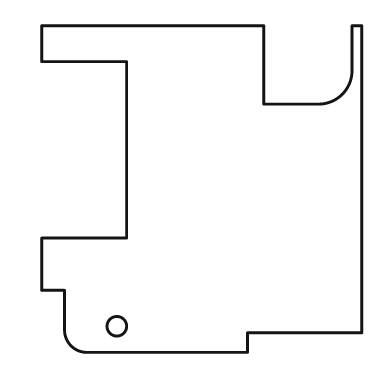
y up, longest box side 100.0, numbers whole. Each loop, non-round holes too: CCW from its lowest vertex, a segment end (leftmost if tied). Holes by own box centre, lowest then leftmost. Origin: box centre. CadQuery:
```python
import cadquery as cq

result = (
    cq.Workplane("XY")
    .moveTo(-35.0, -50.0)
    .lineTo(14.0, -50.0)
    .lineTo(14.0, -44.0)
    .lineTo(49.0, -44.0)
    .lineTo(49.0, 50.0)
    .lineTo(46.0, 50.0)
    .lineTo(46.0, 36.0)
    .threePointArc((43.0, 29.0), (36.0, 26.0))
    .lineTo(19.0, 26.0)
    .lineTo(19.0, 50.0)
    .lineTo(-49.0, 50.0)
    .lineTo(-49.0, 39.0)
    .lineTo(-23.0, 39.0)
    .lineTo(-23.0, -15.0)
    .lineTo(-49.0, -15.0)
    .lineTo(-49.0, -31.0)
    .lineTo(-42.0, -31.0)
    .lineTo(-42.0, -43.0)
    .threePointArc((-40.0, -48.0), (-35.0, -50.0))
    .close()
    .moveTo(-26.0, -42.0)
    .circle(3.0)
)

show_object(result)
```